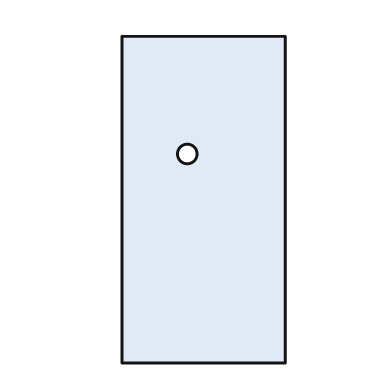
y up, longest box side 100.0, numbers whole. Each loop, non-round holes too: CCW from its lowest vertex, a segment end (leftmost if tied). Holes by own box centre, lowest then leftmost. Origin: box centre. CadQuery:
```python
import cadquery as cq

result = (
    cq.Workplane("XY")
    .moveTo(-25.0, -50.0)
    .lineTo(25.0, -50.0)
    .lineTo(25.0, 50.0)
    .lineTo(-25.0, 50.0)
    .close()
    .moveTo(-5.0, 14.0)
    .circle(3.0)
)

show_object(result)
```